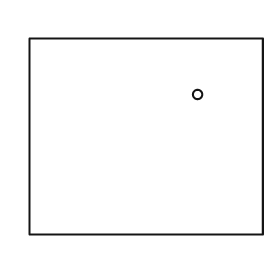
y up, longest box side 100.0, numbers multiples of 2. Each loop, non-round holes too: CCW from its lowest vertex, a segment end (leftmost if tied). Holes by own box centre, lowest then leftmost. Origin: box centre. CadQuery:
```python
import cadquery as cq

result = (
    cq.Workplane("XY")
    .moveTo(-50.0, -42.0)
    .lineTo(50.0, -42.0)
    .lineTo(50.0, 42.0)
    .lineTo(-50.0, 42.0)
    .close()
    .moveTo(22.0, 18.0)
    .circle(2.0)
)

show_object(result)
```